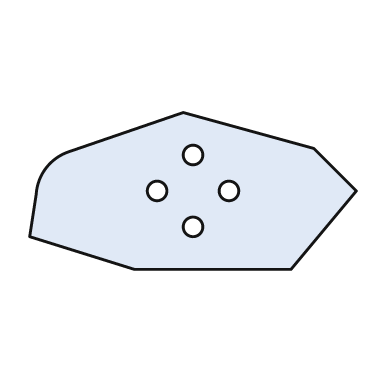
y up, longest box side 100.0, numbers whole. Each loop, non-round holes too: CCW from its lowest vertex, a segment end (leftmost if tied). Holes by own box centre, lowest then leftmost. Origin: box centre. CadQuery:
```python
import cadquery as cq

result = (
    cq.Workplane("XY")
    .moveTo(-18.0, -24.0)
    .lineTo(30.0, -24.0)
    .lineTo(50.0, 0.0)
    .lineTo(37.0, 13.0)
    .lineTo(-3.0, 24.0)
    .lineTo(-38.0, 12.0)
    .threePointArc((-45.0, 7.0), (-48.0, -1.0))
    .lineTo(-50.0, -14.0)
    .close()
    .moveTo(0.0, -11.0)
    .circle(3.0)
    .moveTo(-11.0, 0.0)
    .circle(3.0)
    .moveTo(11.0, 0.0)
    .circle(3.0)
    .moveTo(0.0, 11.0)
    .circle(3.0)
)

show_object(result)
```